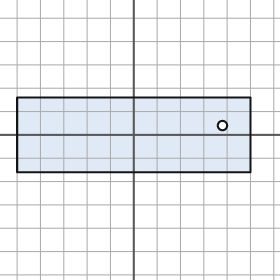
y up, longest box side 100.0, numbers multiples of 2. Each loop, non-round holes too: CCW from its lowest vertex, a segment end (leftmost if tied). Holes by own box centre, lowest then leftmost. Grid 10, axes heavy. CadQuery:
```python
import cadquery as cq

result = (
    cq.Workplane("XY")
    .moveTo(-50.0, -16.0)
    .lineTo(50.0, -16.0)
    .lineTo(50.0, 16.0)
    .lineTo(-50.0, 16.0)
    .close()
    .moveTo(38.0, 4.0)
    .circle(2.0)
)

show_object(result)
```